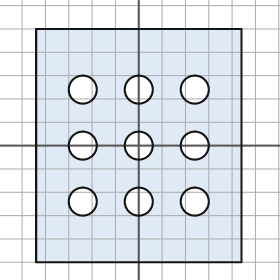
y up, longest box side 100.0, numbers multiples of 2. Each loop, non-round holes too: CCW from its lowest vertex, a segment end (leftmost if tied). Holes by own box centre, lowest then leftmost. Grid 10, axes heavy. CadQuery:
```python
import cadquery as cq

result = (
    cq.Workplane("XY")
    .moveTo(-44.0, -50.0)
    .lineTo(44.0, -50.0)
    .lineTo(44.0, 50.0)
    .lineTo(-44.0, 50.0)
    .close()
    .moveTo(-24.0, -24.0)
    .circle(6.0)
    .moveTo(0.0, -24.0)
    .circle(6.0)
    .moveTo(24.0, -24.0)
    .circle(6.0)
    .moveTo(-24.0, 0.0)
    .circle(6.0)
    .moveTo(0.0, 0.0)
    .circle(6.0)
    .moveTo(24.0, 0.0)
    .circle(6.0)
    .moveTo(-24.0, 24.0)
    .circle(6.0)
    .moveTo(0.0, 24.0)
    .circle(6.0)
    .moveTo(24.0, 24.0)
    .circle(6.0)
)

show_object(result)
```